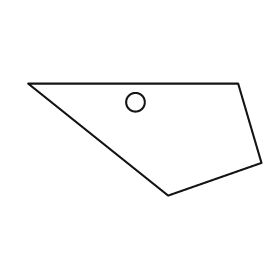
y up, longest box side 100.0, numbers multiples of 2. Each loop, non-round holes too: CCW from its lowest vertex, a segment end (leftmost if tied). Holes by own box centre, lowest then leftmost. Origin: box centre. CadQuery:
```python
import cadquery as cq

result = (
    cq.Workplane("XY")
    .moveTo(10.0, -24.0)
    .lineTo(50.0, -10.0)
    .lineTo(40.0, 24.0)
    .lineTo(-50.0, 24.0)
    .close()
    .moveTo(-4.0, 16.0)
    .circle(4.0)
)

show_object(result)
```